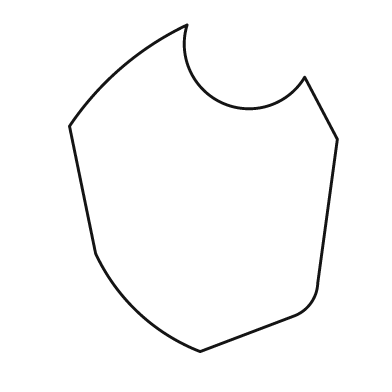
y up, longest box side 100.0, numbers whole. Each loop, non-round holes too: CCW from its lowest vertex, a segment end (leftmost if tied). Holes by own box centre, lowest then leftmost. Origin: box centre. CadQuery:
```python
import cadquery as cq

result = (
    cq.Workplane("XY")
    .moveTo(-1.0, -50.0)
    .lineTo(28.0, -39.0)
    .threePointArc((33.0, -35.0), (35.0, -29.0))
    .lineTo(41.0, 15.0)
    .lineTo(31.0, 34.0)
    .threePointArc((6.0, 26.0), (-5.0, 50.0))
    .threePointArc((-25.0, 37.0), (-41.0, 19.0))
    .lineTo(-33.0, -20.0)
    .threePointArc((-20.0, -38.0), (-1.0, -50.0))
    .close()
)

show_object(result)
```